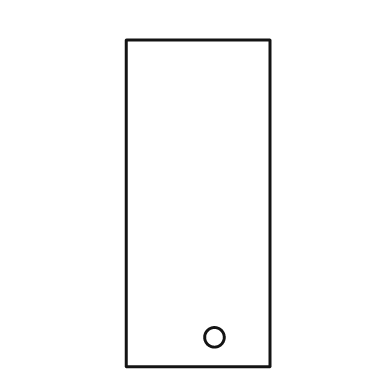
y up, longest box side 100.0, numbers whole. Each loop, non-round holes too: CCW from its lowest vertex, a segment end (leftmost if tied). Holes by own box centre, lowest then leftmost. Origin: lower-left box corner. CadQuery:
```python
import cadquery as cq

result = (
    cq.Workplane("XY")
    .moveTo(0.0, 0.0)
    .lineTo(44.0, 0.0)
    .lineTo(44.0, 100.0)
    .lineTo(0.0, 100.0)
    .close()
    .moveTo(27.0, 9.0)
    .circle(3.0)
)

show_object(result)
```